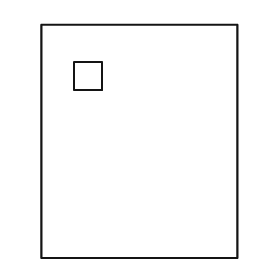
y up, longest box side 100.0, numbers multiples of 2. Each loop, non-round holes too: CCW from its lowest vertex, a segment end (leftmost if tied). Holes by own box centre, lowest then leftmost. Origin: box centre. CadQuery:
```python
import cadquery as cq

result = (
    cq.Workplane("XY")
    .moveTo(-42.0, -50.0)
    .lineTo(42.0, -50.0)
    .lineTo(42.0, 50.0)
    .lineTo(-42.0, 50.0)
    .close()
    .moveTo(-28.0, 22.0)
    .lineTo(-16.0, 22.0)
    .lineTo(-16.0, 34.0)
    .lineTo(-28.0, 34.0)
    .close()
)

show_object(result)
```